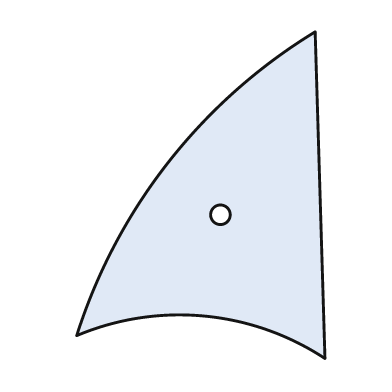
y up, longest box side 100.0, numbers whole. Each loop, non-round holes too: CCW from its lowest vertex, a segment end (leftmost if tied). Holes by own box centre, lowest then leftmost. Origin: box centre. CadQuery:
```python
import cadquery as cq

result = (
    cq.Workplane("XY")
    .moveTo(38.0, -50.0)
    .lineTo(35.0, 50.0)
    .threePointArc((-10.0, 10.0), (-38.0, -43.0))
    .threePointArc((1.0, -37.0), (38.0, -50.0))
    .close()
    .moveTo(6.0, -6.0)
    .circle(3.0)
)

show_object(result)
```